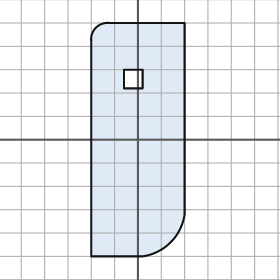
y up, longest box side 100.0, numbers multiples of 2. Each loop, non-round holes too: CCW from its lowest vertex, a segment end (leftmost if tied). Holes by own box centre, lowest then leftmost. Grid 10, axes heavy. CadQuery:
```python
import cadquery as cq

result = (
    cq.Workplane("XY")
    .moveTo(-20.0, -50.0)
    .lineTo(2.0, -50.0)
    .threePointArc((14.0, -44.0), (20.0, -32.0))
    .lineTo(20.0, 50.0)
    .lineTo(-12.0, 50.0)
    .threePointArc((-18.0, 48.0), (-20.0, 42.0))
    .close()
    .moveTo(-6.0, 22.0)
    .lineTo(2.0, 22.0)
    .lineTo(2.0, 30.0)
    .lineTo(-6.0, 30.0)
    .close()
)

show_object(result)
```